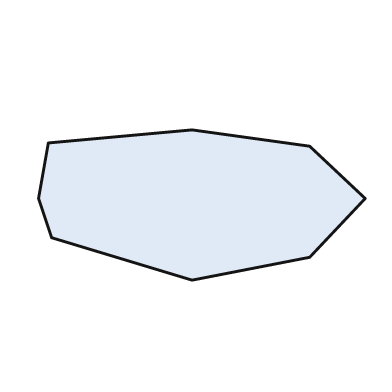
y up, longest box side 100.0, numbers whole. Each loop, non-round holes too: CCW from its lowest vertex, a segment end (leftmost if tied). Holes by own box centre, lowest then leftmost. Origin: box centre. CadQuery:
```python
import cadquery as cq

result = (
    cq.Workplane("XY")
    .moveTo(-3.0, -23.0)
    .lineTo(33.0, -16.0)
    .lineTo(50.0, 2.0)
    .lineTo(33.0, 18.0)
    .lineTo(-3.0, 23.0)
    .lineTo(-47.0, 19.0)
    .lineTo(-50.0, 2.0)
    .lineTo(-46.0, -10.0)
    .close()
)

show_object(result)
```